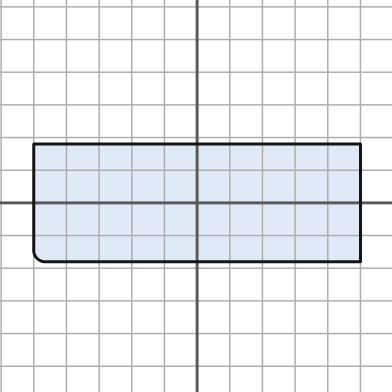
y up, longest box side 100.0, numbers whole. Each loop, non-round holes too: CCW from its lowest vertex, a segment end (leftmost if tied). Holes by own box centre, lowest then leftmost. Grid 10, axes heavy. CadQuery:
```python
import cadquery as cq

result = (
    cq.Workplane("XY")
    .moveTo(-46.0, -18.0)
    .lineTo(50.0, -18.0)
    .lineTo(50.0, 18.0)
    .lineTo(-50.0, 18.0)
    .lineTo(-50.0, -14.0)
    .threePointArc((-49.0, -17.0), (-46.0, -18.0))
    .close()
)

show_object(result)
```